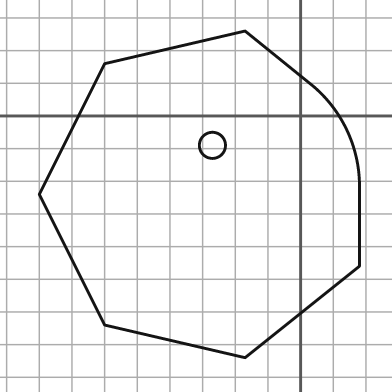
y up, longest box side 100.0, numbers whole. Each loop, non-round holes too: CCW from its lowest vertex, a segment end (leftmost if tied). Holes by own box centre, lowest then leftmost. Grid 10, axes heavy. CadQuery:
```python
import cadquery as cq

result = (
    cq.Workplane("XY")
    .moveTo(-17.0, -74.0)
    .lineTo(18.0, -46.0)
    .lineTo(18.0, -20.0)
    .threePointArc((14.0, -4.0), (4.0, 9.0))
    .lineTo(-17.0, 26.0)
    .lineTo(-60.0, 16.0)
    .lineTo(-80.0, -24.0)
    .lineTo(-60.0, -64.0)
    .close()
    .moveTo(-27.0, -9.0)
    .circle(4.0)
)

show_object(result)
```